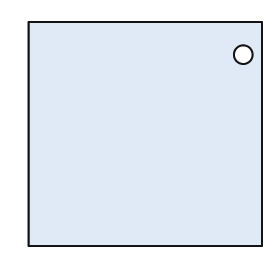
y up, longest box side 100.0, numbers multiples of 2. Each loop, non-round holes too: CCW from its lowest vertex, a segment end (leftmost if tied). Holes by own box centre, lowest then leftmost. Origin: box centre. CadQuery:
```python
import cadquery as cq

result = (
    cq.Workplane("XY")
    .moveTo(-50.0, -48.0)
    .lineTo(50.0, -48.0)
    .lineTo(50.0, 48.0)
    .lineTo(-50.0, 48.0)
    .close()
    .moveTo(42.0, 34.0)
    .circle(4.0)
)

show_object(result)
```